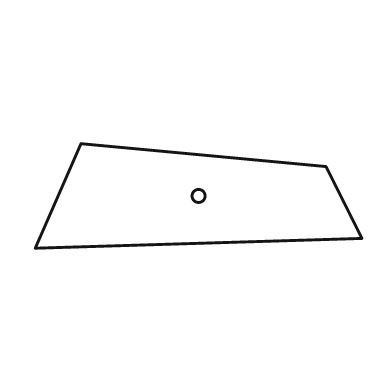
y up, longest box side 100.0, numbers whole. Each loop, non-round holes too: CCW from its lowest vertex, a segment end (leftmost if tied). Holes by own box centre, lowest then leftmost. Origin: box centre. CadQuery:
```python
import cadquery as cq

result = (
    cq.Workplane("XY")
    .moveTo(-50.0, -16.0)
    .lineTo(50.0, -13.0)
    .lineTo(39.0, 9.0)
    .lineTo(-36.0, 16.0)
    .close()
    .moveTo(0.0, 0.0)
    .circle(2.0)
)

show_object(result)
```